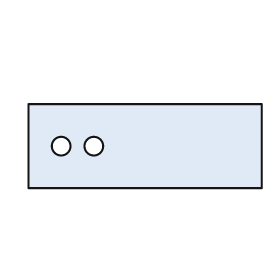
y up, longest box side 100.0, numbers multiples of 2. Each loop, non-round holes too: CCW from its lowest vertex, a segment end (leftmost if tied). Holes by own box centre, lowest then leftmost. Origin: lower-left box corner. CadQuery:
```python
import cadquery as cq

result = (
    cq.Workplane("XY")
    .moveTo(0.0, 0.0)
    .lineTo(100.0, 0.0)
    .lineTo(100.0, 36.0)
    .lineTo(0.0, 36.0)
    .close()
    .moveTo(14.0, 18.0)
    .circle(4.0)
    .moveTo(28.0, 18.0)
    .circle(4.0)
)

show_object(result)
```